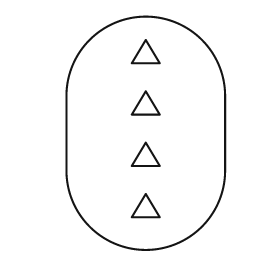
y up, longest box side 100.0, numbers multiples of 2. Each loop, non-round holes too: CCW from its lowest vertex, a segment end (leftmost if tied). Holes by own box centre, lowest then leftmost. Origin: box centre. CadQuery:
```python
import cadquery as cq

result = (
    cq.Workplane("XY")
    .moveTo(-34.0, -16.0)
    .threePointArc((0.0, -50.0), (34.0, -16.0))
    .lineTo(34.0, 16.0)
    .threePointArc((0.0, 50.0), (-34.0, 16.0))
    .close()
    .moveTo(-6.0, -36.0)
    .lineTo(6.0, -36.0)
    .lineTo(0.0, -26.0)
    .close()
    .moveTo(-6.0, -14.0)
    .lineTo(6.0, -14.0)
    .lineTo(0.0, -4.0)
    .close()
    .moveTo(-6.0, 8.0)
    .lineTo(6.0, 8.0)
    .lineTo(0.0, 18.0)
    .close()
    .moveTo(-6.0, 30.0)
    .lineTo(6.0, 30.0)
    .lineTo(0.0, 40.0)
    .close()
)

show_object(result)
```